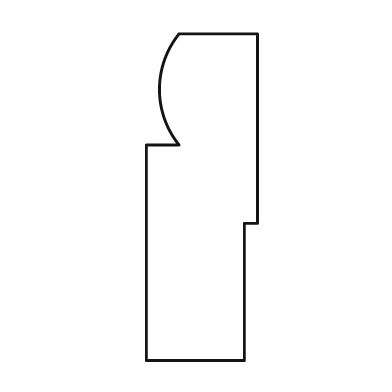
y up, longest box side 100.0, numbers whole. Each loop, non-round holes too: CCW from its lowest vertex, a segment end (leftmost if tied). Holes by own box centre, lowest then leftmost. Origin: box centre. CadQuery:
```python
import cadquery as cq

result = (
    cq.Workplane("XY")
    .moveTo(-17.0, -50.0)
    .lineTo(13.0, -50.0)
    .lineTo(13.0, -8.0)
    .lineTo(17.0, -8.0)
    .lineTo(17.0, 50.0)
    .lineTo(-7.0, 50.0)
    .threePointArc((-13.0, 33.0), (-7.0, 16.0))
    .lineTo(-17.0, 16.0)
    .close()
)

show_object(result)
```